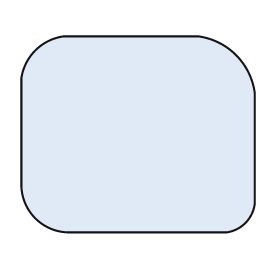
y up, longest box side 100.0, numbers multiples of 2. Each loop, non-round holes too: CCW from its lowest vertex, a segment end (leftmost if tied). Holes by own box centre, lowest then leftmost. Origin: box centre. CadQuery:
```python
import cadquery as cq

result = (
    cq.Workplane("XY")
    .moveTo(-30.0, -42.0)
    .lineTo(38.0, -42.0)
    .threePointArc((46.0, -38.0), (50.0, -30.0))
    .lineTo(50.0, 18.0)
    .threePointArc((42.0, 34.0), (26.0, 42.0))
    .lineTo(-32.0, 42.0)
    .threePointArc((-44.0, 36.0), (-50.0, 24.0))
    .lineTo(-50.0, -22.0)
    .threePointArc((-44.0, -36.0), (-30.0, -42.0))
    .close()
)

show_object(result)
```